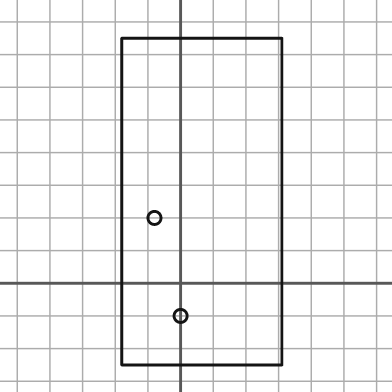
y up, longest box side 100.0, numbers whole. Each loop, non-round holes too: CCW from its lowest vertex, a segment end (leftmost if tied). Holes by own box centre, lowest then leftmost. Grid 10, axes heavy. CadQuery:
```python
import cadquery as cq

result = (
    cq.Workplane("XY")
    .moveTo(-18.0, -25.0)
    .lineTo(31.0, -25.0)
    .lineTo(31.0, 75.0)
    .lineTo(-18.0, 75.0)
    .close()
    .moveTo(0.0, -10.0)
    .circle(2.0)
    .moveTo(-8.0, 20.0)
    .circle(2.0)
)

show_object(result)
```